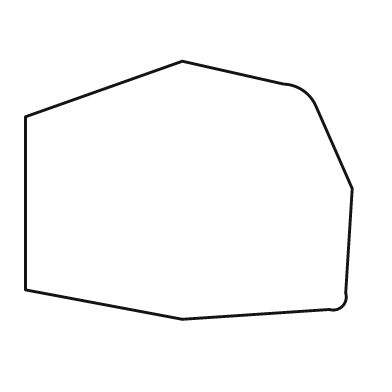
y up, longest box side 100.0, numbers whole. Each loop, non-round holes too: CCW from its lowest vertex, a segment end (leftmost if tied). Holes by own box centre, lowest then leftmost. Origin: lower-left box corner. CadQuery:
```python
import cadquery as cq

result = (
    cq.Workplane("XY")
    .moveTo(48.0, 0.0)
    .lineTo(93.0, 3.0)
    .threePointArc((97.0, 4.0), (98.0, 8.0))
    .lineTo(100.0, 40.0)
    .lineTo(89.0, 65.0)
    .threePointArc((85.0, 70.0), (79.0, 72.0))
    .lineTo(48.0, 79.0)
    .lineTo(0.0, 62.0)
    .lineTo(0.0, 9.0)
    .close()
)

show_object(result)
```